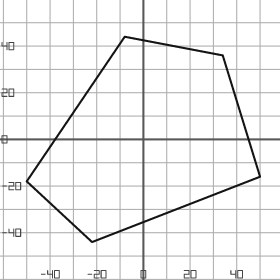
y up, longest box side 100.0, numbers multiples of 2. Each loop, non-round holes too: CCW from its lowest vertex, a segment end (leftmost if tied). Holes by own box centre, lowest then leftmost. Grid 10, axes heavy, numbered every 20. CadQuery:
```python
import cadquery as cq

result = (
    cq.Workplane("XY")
    .moveTo(-22.0, -44.0)
    .lineTo(50.0, -16.0)
    .lineTo(34.0, 36.0)
    .lineTo(-8.0, 44.0)
    .lineTo(-50.0, -18.0)
    .close()
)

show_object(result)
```